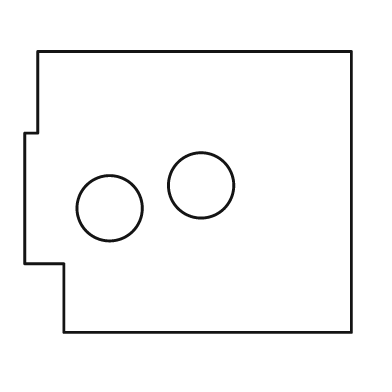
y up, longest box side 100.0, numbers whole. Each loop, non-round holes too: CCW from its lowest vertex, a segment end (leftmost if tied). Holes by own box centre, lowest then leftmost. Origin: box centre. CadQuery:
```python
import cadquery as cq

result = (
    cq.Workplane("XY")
    .moveTo(-38.0, -43.0)
    .lineTo(50.0, -43.0)
    .lineTo(50.0, 43.0)
    .lineTo(-46.0, 43.0)
    .lineTo(-46.0, 18.0)
    .lineTo(-50.0, 18.0)
    .lineTo(-50.0, -22.0)
    .lineTo(-38.0, -22.0)
    .close()
    .moveTo(-24.0, -5.0)
    .circle(10.0)
    .moveTo(4.0, 2.0)
    .circle(10.0)
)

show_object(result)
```